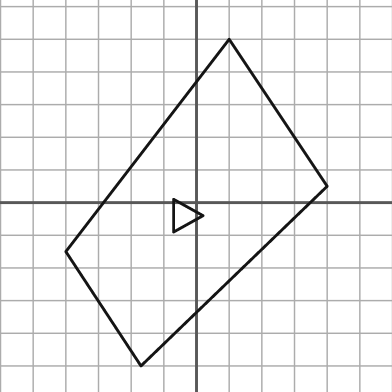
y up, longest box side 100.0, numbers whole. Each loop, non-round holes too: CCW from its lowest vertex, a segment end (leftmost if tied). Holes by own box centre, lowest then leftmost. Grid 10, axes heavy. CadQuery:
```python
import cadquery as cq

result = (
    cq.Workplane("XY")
    .moveTo(-17.0, -50.0)
    .lineTo(40.0, 5.0)
    .lineTo(10.0, 50.0)
    .lineTo(-40.0, -15.0)
    .close()
    .moveTo(-7.0, -9.0)
    .lineTo(2.0, -4.0)
    .lineTo(-7.0, 1.0)
    .close()
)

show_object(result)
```